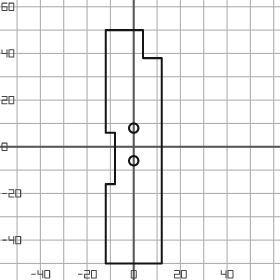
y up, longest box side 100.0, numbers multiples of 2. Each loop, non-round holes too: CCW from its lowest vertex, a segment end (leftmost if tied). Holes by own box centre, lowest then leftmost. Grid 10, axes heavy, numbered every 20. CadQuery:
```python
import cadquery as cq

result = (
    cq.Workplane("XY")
    .moveTo(-12.0, -50.0)
    .lineTo(12.0, -50.0)
    .lineTo(12.0, 38.0)
    .lineTo(4.0, 38.0)
    .lineTo(4.0, 50.0)
    .lineTo(-12.0, 50.0)
    .lineTo(-12.0, 6.0)
    .lineTo(-8.0, 6.0)
    .lineTo(-8.0, -16.0)
    .lineTo(-12.0, -16.0)
    .close()
    .moveTo(0.0, -6.0)
    .circle(2.0)
    .moveTo(0.0, 8.0)
    .circle(2.0)
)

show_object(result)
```